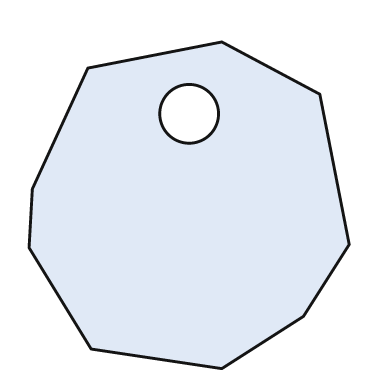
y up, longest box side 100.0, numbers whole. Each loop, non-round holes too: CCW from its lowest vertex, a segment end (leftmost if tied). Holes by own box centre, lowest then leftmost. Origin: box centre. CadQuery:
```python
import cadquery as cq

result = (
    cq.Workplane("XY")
    .moveTo(10.0, -50.0)
    .lineTo(35.0, -34.0)
    .lineTo(49.0, -12.0)
    .lineTo(40.0, 34.0)
    .lineTo(10.0, 50.0)
    .lineTo(-31.0, 42.0)
    .lineTo(-48.0, 5.0)
    .lineTo(-49.0, -13.0)
    .lineTo(-30.0, -44.0)
    .close()
    .moveTo(0.0, 28.0)
    .circle(9.0)
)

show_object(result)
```